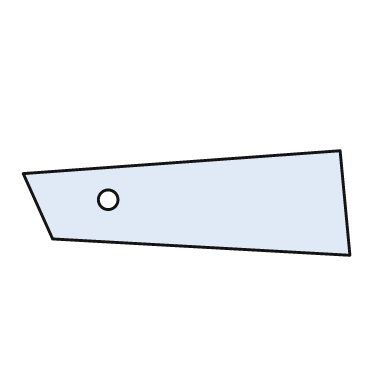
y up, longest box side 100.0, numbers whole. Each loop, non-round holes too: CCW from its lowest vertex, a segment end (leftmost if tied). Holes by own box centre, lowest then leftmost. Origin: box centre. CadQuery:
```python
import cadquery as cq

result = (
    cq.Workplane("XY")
    .moveTo(50.0, -16.0)
    .lineTo(47.0, 16.0)
    .lineTo(-50.0, 9.0)
    .lineTo(-41.0, -11.0)
    .close()
    .moveTo(-24.0, 1.0)
    .circle(3.0)
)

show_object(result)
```